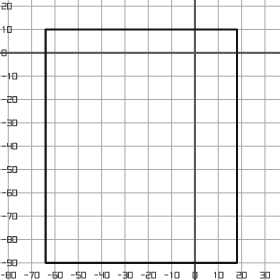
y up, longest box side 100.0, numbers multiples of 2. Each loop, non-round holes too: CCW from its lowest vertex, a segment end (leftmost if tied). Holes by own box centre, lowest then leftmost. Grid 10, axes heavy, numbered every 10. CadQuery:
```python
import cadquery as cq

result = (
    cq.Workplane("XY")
    .moveTo(-64.0, -90.0)
    .lineTo(18.0, -90.0)
    .lineTo(18.0, 10.0)
    .lineTo(-64.0, 10.0)
    .close()
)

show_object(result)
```